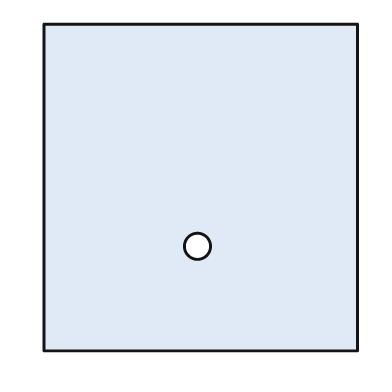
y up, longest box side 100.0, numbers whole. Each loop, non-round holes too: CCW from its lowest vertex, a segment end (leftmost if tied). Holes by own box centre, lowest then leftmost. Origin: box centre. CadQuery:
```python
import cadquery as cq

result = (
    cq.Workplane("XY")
    .moveTo(-48.0, -50.0)
    .lineTo(48.0, -50.0)
    .lineTo(48.0, 50.0)
    .lineTo(-48.0, 50.0)
    .close()
    .moveTo(-1.0, -18.0)
    .circle(4.0)
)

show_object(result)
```